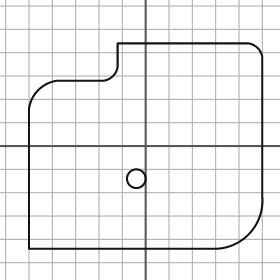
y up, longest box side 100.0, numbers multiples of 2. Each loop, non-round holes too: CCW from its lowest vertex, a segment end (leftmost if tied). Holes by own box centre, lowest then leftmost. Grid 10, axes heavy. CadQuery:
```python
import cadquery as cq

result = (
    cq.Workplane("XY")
    .moveTo(-50.0, -44.0)
    .lineTo(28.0, -44.0)
    .threePointArc((44.0, -38.0), (50.0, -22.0))
    .lineTo(50.0, 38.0)
    .threePointArc((48.0, 42.0), (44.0, 44.0))
    .lineTo(-12.0, 44.0)
    .lineTo(-12.0, 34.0)
    .threePointArc((-14.0, 30.0), (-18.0, 28.0))
    .lineTo(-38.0, 28.0)
    .threePointArc((-46.0, 24.0), (-50.0, 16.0))
    .close()
    .moveTo(-4.0, -14.0)
    .circle(4.0)
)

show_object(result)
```